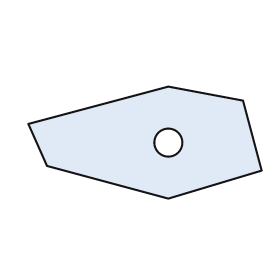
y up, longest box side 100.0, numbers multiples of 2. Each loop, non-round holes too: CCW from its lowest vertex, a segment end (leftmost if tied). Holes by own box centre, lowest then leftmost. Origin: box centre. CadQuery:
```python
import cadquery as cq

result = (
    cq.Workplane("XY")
    .moveTo(10.0, -24.0)
    .lineTo(50.0, -12.0)
    .lineTo(42.0, 18.0)
    .lineTo(10.0, 24.0)
    .lineTo(-50.0, 8.0)
    .lineTo(-42.0, -10.0)
    .close()
    .moveTo(10.0, 0.0)
    .circle(6.0)
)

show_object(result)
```